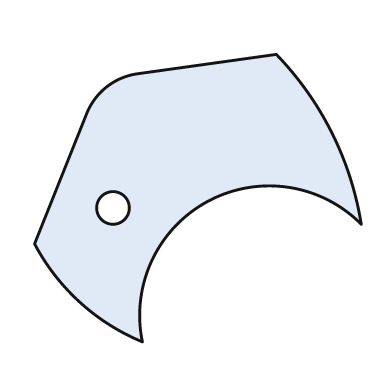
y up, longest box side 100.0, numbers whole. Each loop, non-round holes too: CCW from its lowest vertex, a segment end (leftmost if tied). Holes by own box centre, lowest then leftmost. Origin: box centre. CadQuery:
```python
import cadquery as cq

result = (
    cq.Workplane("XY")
    .moveTo(-17.0, -44.0)
    .threePointArc((3.0, -1.0), (50.0, -8.0))
    .threePointArc((41.0, 20.0), (24.0, 44.0))
    .lineTo(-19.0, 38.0)
    .threePointArc((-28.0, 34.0), (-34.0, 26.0))
    .lineTo(-50.0, -14.0)
    .threePointArc((-36.0, -32.0), (-17.0, -44.0))
    .close()
    .moveTo(-26.0, -3.0)
    .circle(5.0)
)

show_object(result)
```